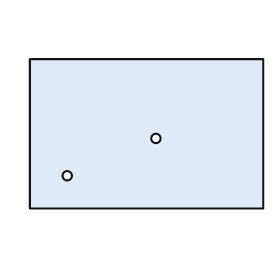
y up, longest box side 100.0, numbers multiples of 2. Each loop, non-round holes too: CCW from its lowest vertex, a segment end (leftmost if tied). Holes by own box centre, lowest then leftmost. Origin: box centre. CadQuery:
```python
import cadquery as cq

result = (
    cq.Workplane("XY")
    .moveTo(-50.0, -32.0)
    .lineTo(50.0, -32.0)
    .lineTo(50.0, 32.0)
    .lineTo(-50.0, 32.0)
    .close()
    .moveTo(-34.0, -18.0)
    .circle(2.0)
    .moveTo(4.0, -2.0)
    .circle(2.0)
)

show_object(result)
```